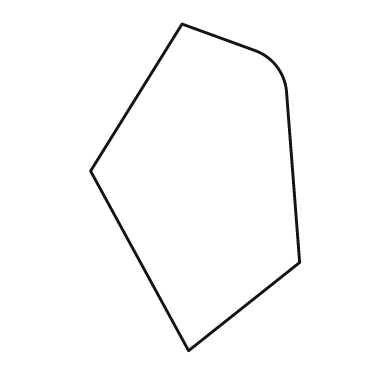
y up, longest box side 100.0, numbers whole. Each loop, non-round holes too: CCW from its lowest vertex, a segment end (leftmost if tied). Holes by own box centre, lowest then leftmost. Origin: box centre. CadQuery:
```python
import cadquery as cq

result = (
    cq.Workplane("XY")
    .moveTo(-2.0, -50.0)
    .lineTo(32.0, -23.0)
    .lineTo(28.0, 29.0)
    .threePointArc((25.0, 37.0), (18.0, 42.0))
    .lineTo(-4.0, 50.0)
    .lineTo(-32.0, 5.0)
    .close()
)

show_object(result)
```